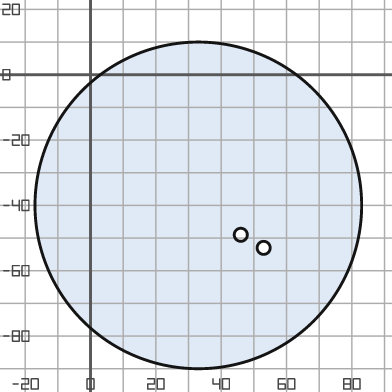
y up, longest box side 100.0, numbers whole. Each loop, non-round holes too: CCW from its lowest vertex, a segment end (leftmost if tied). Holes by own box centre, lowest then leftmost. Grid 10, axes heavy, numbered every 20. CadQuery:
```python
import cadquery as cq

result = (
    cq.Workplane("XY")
    .moveTo(33.0, -40.0)
    .circle(50.0)
    .moveTo(53.0, -53.0)
    .circle(2.0)
    .moveTo(46.0, -49.0)
    .circle(2.0)
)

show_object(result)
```